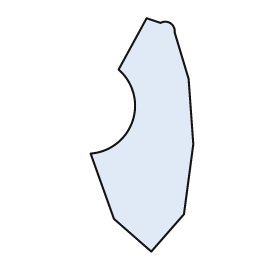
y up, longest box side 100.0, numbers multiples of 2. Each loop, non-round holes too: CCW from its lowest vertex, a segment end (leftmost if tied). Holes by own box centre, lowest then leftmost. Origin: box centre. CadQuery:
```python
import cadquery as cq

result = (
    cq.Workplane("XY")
    .moveTo(4.0, -50.0)
    .lineTo(18.0, -34.0)
    .lineTo(22.0, -4.0)
    .lineTo(20.0, 24.0)
    .lineTo(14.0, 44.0)
    .threePointArc((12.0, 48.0), (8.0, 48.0))
    .lineTo(2.0, 50.0)
    .lineTo(-10.0, 28.0)
    .threePointArc((-4.0, 6.0), (-22.0, -8.0))
    .lineTo(-12.0, -36.0)
    .close()
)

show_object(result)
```